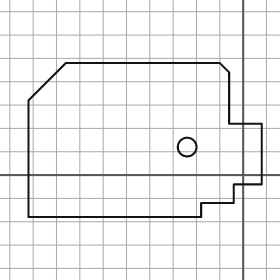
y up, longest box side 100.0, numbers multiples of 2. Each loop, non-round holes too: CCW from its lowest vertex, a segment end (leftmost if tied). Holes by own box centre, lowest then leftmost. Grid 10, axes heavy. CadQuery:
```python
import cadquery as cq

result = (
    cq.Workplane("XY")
    .moveTo(-92.0, -18.0)
    .lineTo(-18.0, -18.0)
    .lineTo(-18.0, -12.0)
    .lineTo(-4.0, -12.0)
    .lineTo(-4.0, -4.0)
    .lineTo(8.0, -4.0)
    .lineTo(8.0, 22.0)
    .lineTo(-6.0, 22.0)
    .lineTo(-6.0, 44.0)
    .lineTo(-10.0, 48.0)
    .lineTo(-76.0, 48.0)
    .lineTo(-92.0, 32.0)
    .close()
    .moveTo(-24.0, 12.0)
    .circle(4.0)
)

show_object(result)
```